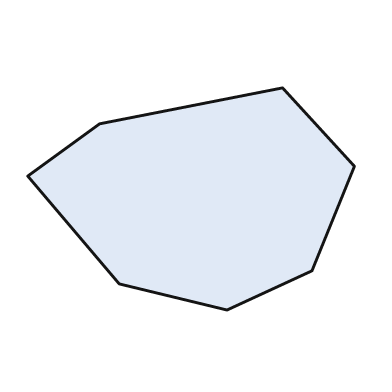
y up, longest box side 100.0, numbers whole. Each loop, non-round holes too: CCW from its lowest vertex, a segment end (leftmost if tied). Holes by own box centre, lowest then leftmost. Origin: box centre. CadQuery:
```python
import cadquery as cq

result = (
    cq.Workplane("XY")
    .moveTo(11.0, -34.0)
    .lineTo(37.0, -22.0)
    .lineTo(50.0, 10.0)
    .lineTo(28.0, 34.0)
    .lineTo(-28.0, 23.0)
    .lineTo(-50.0, 7.0)
    .lineTo(-22.0, -26.0)
    .close()
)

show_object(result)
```